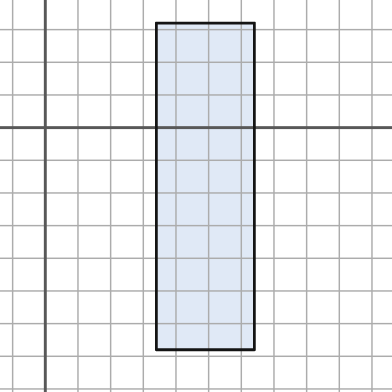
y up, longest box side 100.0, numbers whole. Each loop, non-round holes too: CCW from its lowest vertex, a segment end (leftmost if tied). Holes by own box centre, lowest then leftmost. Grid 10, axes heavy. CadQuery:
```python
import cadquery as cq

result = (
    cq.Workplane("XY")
    .moveTo(34.0, -68.0)
    .lineTo(64.0, -68.0)
    .lineTo(64.0, 32.0)
    .lineTo(34.0, 32.0)
    .close()
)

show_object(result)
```